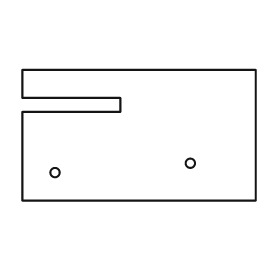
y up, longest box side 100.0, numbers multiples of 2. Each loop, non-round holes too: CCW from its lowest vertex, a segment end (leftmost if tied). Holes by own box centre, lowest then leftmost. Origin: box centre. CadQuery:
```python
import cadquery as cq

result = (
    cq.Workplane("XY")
    .moveTo(-50.0, -28.0)
    .lineTo(50.0, -28.0)
    .lineTo(50.0, 28.0)
    .lineTo(-50.0, 28.0)
    .lineTo(-50.0, 16.0)
    .lineTo(-8.0, 16.0)
    .lineTo(-8.0, 10.0)
    .lineTo(-50.0, 10.0)
    .close()
    .moveTo(-36.0, -16.0)
    .circle(2.0)
    .moveTo(22.0, -12.0)
    .circle(2.0)
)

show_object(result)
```